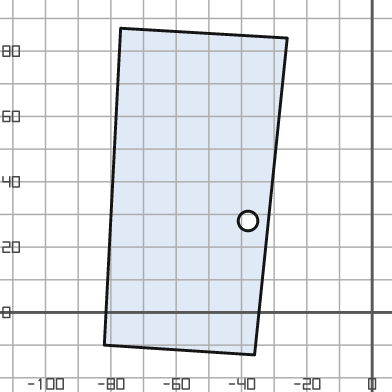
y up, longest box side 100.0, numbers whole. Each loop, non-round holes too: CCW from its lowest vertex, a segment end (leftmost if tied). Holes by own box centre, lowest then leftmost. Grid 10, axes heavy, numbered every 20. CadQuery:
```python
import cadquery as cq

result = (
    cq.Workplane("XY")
    .moveTo(-36.0, -13.0)
    .lineTo(-26.0, 84.0)
    .lineTo(-77.0, 87.0)
    .lineTo(-82.0, -10.0)
    .close()
    .moveTo(-38.0, 28.0)
    .circle(3.0)
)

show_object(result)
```